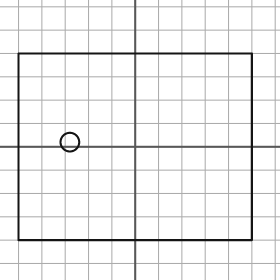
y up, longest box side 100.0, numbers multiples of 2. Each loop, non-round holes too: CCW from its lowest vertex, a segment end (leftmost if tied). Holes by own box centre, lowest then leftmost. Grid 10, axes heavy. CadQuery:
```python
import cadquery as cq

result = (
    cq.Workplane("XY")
    .moveTo(-50.0, -40.0)
    .lineTo(50.0, -40.0)
    .lineTo(50.0, 40.0)
    .lineTo(-50.0, 40.0)
    .close()
    .moveTo(-28.0, 2.0)
    .circle(4.0)
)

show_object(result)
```